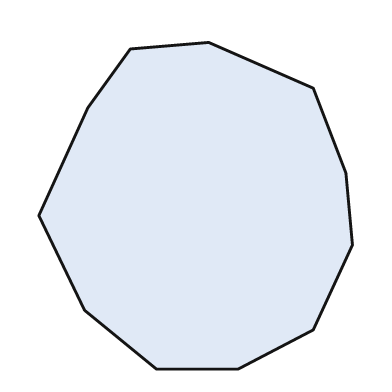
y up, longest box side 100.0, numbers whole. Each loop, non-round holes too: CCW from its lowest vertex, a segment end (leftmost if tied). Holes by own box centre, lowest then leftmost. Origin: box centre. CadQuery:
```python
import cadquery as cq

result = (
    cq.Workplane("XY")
    .moveTo(-12.0, -50.0)
    .lineTo(13.0, -50.0)
    .lineTo(36.0, -38.0)
    .lineTo(48.0, -12.0)
    .lineTo(46.0, 10.0)
    .lineTo(36.0, 36.0)
    .lineTo(4.0, 50.0)
    .lineTo(-20.0, 48.0)
    .lineTo(-33.0, 30.0)
    .lineTo(-48.0, -3.0)
    .lineTo(-34.0, -32.0)
    .close()
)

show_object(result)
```